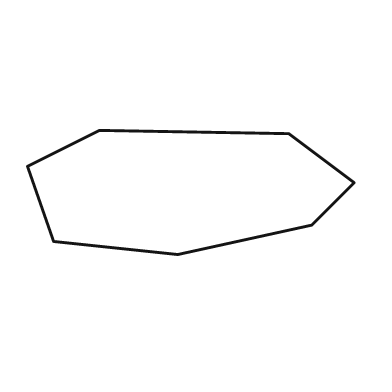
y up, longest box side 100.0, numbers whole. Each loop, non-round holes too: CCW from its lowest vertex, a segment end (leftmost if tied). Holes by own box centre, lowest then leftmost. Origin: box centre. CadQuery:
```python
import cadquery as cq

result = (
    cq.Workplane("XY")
    .moveTo(-4.0, -19.0)
    .lineTo(37.0, -10.0)
    .lineTo(50.0, 3.0)
    .lineTo(30.0, 18.0)
    .lineTo(-28.0, 19.0)
    .lineTo(-50.0, 8.0)
    .lineTo(-42.0, -15.0)
    .close()
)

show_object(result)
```